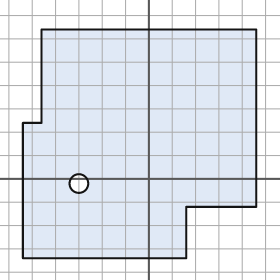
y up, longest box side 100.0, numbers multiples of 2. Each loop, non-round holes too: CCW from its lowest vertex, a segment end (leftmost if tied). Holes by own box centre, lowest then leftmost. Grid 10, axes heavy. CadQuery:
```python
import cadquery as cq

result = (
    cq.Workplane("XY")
    .moveTo(-54.0, -34.0)
    .lineTo(16.0, -34.0)
    .lineTo(16.0, -12.0)
    .lineTo(46.0, -12.0)
    .lineTo(46.0, 64.0)
    .lineTo(-46.0, 64.0)
    .lineTo(-46.0, 24.0)
    .lineTo(-54.0, 24.0)
    .close()
    .moveTo(-30.0, -2.0)
    .circle(4.0)
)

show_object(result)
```